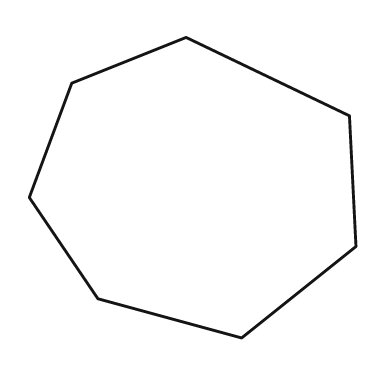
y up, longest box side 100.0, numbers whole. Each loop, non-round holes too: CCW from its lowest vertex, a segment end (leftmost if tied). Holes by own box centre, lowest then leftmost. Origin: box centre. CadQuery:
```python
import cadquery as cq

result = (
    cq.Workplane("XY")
    .moveTo(15.0, -46.0)
    .lineTo(50.0, -18.0)
    .lineTo(48.0, 22.0)
    .lineTo(-2.0, 46.0)
    .lineTo(-37.0, 32.0)
    .lineTo(-50.0, -3.0)
    .lineTo(-29.0, -34.0)
    .close()
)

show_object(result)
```